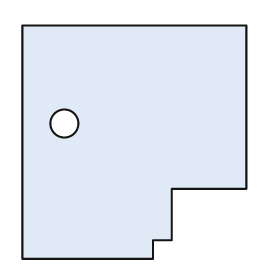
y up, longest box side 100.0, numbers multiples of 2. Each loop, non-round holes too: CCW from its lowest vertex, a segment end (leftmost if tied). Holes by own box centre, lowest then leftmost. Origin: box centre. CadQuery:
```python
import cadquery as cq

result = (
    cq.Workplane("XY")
    .moveTo(-48.0, -50.0)
    .lineTo(8.0, -50.0)
    .lineTo(8.0, -42.0)
    .lineTo(16.0, -42.0)
    .lineTo(16.0, -20.0)
    .lineTo(48.0, -20.0)
    .lineTo(48.0, 50.0)
    .lineTo(-48.0, 50.0)
    .close()
    .moveTo(-30.0, 8.0)
    .circle(6.0)
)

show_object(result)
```